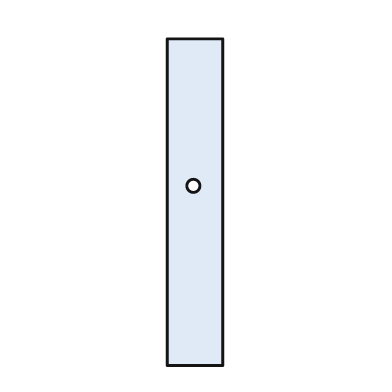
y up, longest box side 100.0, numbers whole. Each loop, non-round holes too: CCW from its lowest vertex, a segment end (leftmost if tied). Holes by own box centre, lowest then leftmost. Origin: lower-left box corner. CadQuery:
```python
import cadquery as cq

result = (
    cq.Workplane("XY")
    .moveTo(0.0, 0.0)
    .lineTo(17.0, 0.0)
    .lineTo(17.0, 100.0)
    .lineTo(0.0, 100.0)
    .close()
    .moveTo(8.0, 55.0)
    .circle(2.0)
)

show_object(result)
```